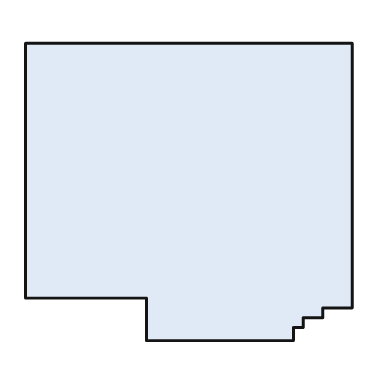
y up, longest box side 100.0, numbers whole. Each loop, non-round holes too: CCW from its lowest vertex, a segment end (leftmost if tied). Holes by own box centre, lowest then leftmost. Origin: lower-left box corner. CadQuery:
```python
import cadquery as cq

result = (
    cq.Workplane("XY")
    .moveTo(37.0, 0.0)
    .lineTo(82.0, 0.0)
    .lineTo(82.0, 4.0)
    .lineTo(85.0, 4.0)
    .lineTo(85.0, 7.0)
    .lineTo(91.0, 7.0)
    .lineTo(91.0, 10.0)
    .lineTo(100.0, 10.0)
    .lineTo(100.0, 91.0)
    .lineTo(0.0, 91.0)
    .lineTo(0.0, 13.0)
    .lineTo(37.0, 13.0)
    .close()
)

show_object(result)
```